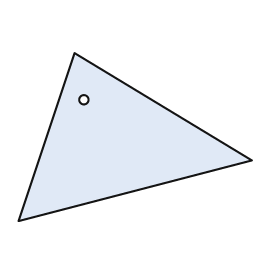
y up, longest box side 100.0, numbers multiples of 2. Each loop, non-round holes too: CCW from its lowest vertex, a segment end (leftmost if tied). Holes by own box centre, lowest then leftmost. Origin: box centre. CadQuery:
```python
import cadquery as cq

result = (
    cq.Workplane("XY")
    .moveTo(-50.0, -36.0)
    .lineTo(50.0, -10.0)
    .lineTo(-26.0, 36.0)
    .close()
    .moveTo(-22.0, 16.0)
    .circle(2.0)
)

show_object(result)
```